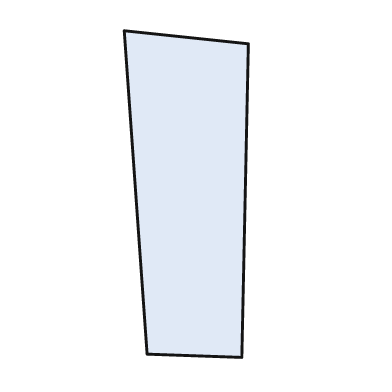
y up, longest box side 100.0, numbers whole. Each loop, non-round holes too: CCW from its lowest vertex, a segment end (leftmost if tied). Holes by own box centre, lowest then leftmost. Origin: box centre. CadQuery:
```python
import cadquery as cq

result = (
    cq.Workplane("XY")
    .moveTo(17.0, -50.0)
    .lineTo(19.0, 46.0)
    .lineTo(-19.0, 50.0)
    .lineTo(-12.0, -49.0)
    .close()
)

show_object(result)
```